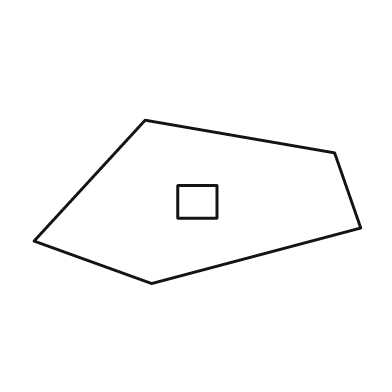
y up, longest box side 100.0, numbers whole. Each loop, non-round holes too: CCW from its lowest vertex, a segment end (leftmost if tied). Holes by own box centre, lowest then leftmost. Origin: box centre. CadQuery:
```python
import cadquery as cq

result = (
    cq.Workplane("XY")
    .moveTo(-14.0, -25.0)
    .lineTo(50.0, -8.0)
    .lineTo(42.0, 15.0)
    .lineTo(-16.0, 25.0)
    .lineTo(-50.0, -12.0)
    .close()
    .moveTo(-6.0, -5.0)
    .lineTo(6.0, -5.0)
    .lineTo(6.0, 5.0)
    .lineTo(-6.0, 5.0)
    .close()
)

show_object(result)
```